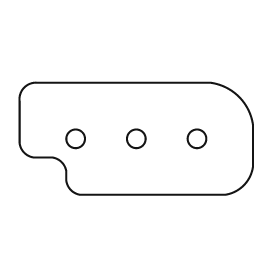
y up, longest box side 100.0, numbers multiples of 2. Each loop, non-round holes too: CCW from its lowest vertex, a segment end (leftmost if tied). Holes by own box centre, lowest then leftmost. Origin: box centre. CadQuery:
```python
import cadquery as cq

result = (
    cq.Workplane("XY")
    .moveTo(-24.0, -24.0)
    .lineTo(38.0, -24.0)
    .threePointArc((46.0, -20.0), (50.0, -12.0))
    .lineTo(50.0, 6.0)
    .threePointArc((44.0, 18.0), (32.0, 24.0))
    .lineTo(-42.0, 24.0)
    .threePointArc((-48.0, 22.0), (-50.0, 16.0))
    .lineTo(-50.0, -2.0)
    .threePointArc((-48.0, -6.0), (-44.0, -8.0))
    .lineTo(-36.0, -8.0)
    .threePointArc((-32.0, -10.0), (-30.0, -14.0))
    .lineTo(-30.0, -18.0)
    .threePointArc((-28.0, -22.0), (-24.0, -24.0))
    .close()
    .moveTo(-26.0, 0.0)
    .circle(4.0)
    .moveTo(0.0, 0.0)
    .circle(4.0)
    .moveTo(26.0, 0.0)
    .circle(4.0)
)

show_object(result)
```